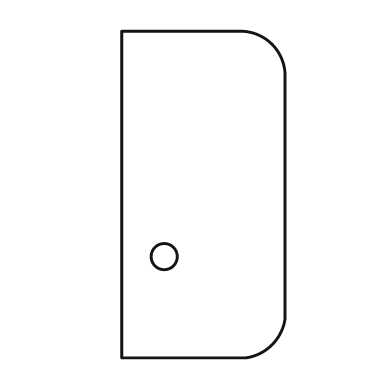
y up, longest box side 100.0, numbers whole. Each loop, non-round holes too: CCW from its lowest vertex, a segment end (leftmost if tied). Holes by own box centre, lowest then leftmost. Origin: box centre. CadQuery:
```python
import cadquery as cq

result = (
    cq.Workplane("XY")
    .moveTo(-25.0, -50.0)
    .lineTo(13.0, -50.0)
    .threePointArc((21.0, -46.0), (25.0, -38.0))
    .lineTo(25.0, 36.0)
    .threePointArc((21.0, 46.0), (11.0, 50.0))
    .lineTo(-25.0, 50.0)
    .close()
    .moveTo(-12.0, -19.0)
    .circle(4.0)
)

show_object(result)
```